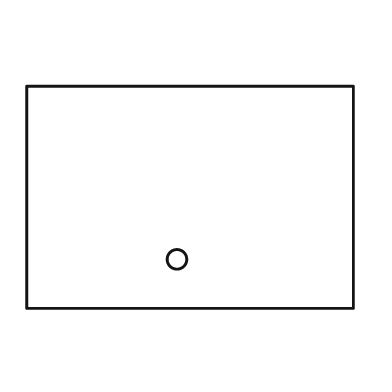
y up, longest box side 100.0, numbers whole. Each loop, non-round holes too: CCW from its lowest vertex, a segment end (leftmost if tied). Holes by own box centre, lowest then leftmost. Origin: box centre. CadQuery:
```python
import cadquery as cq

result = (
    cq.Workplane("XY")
    .moveTo(-50.0, -34.0)
    .lineTo(50.0, -34.0)
    .lineTo(50.0, 34.0)
    .lineTo(-50.0, 34.0)
    .close()
    .moveTo(-4.0, -19.0)
    .circle(3.0)
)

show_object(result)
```